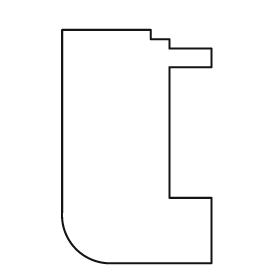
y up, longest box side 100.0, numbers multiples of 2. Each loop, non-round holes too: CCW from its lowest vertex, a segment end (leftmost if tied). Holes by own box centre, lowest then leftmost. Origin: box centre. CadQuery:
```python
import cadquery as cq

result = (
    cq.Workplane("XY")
    .moveTo(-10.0, -50.0)
    .lineTo(32.0, -50.0)
    .lineTo(32.0, -22.0)
    .lineTo(14.0, -22.0)
    .lineTo(14.0, 34.0)
    .lineTo(32.0, 34.0)
    .lineTo(32.0, 42.0)
    .lineTo(14.0, 42.0)
    .lineTo(14.0, 46.0)
    .lineTo(6.0, 46.0)
    .lineTo(6.0, 50.0)
    .lineTo(-32.0, 50.0)
    .lineTo(-32.0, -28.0)
    .threePointArc((-26.0, -44.0), (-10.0, -50.0))
    .close()
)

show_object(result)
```